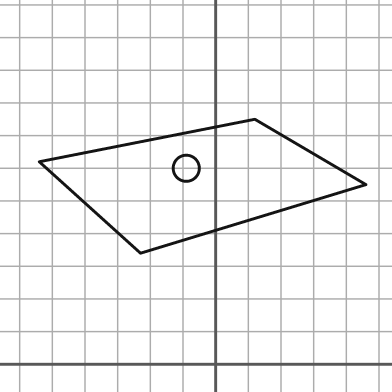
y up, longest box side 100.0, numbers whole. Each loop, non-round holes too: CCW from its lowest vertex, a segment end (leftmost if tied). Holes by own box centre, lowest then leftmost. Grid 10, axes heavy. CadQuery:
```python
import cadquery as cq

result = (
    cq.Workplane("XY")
    .moveTo(-23.0, 34.0)
    .lineTo(46.0, 55.0)
    .lineTo(12.0, 75.0)
    .lineTo(-54.0, 62.0)
    .close()
    .moveTo(-9.0, 60.0)
    .circle(4.0)
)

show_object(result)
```